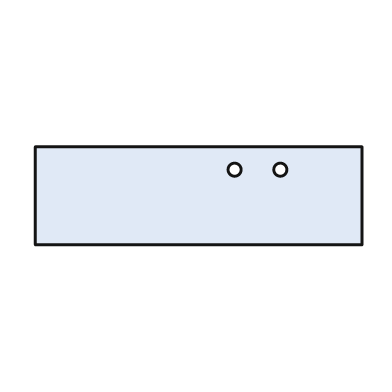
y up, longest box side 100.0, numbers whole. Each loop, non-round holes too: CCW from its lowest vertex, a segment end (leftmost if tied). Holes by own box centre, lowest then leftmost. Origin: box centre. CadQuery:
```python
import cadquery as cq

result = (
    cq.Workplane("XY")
    .moveTo(-50.0, -15.0)
    .lineTo(50.0, -15.0)
    .lineTo(50.0, 15.0)
    .lineTo(-50.0, 15.0)
    .close()
    .moveTo(11.0, 8.0)
    .circle(2.0)
    .moveTo(25.0, 8.0)
    .circle(2.0)
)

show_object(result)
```